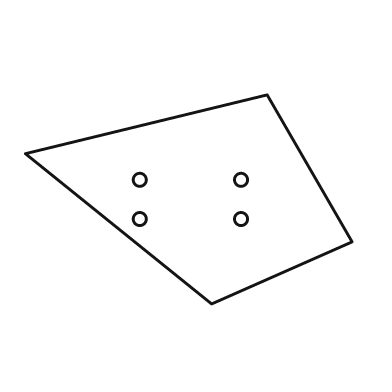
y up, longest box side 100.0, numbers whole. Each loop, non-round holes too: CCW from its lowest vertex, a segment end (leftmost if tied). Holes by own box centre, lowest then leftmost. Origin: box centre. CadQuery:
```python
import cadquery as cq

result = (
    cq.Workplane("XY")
    .moveTo(7.0, -32.0)
    .lineTo(50.0, -13.0)
    .lineTo(24.0, 32.0)
    .lineTo(-50.0, 14.0)
    .close()
    .moveTo(-15.0, -6.0)
    .circle(2.0)
    .moveTo(16.0, -6.0)
    .circle(2.0)
    .moveTo(-15.0, 6.0)
    .circle(2.0)
    .moveTo(16.0, 6.0)
    .circle(2.0)
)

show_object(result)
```